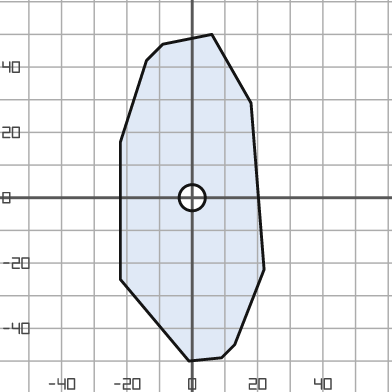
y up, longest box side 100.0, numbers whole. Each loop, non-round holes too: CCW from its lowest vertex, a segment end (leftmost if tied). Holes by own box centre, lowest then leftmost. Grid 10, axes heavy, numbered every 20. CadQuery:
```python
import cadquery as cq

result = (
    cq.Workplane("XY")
    .moveTo(-1.0, -50.0)
    .lineTo(9.0, -49.0)
    .lineTo(13.0, -45.0)
    .lineTo(22.0, -22.0)
    .lineTo(18.0, 29.0)
    .lineTo(6.0, 50.0)
    .lineTo(-9.0, 47.0)
    .lineTo(-14.0, 42.0)
    .lineTo(-22.0, 17.0)
    .lineTo(-22.0, -25.0)
    .close()
    .moveTo(0.0, 0.0)
    .circle(4.0)
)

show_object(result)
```